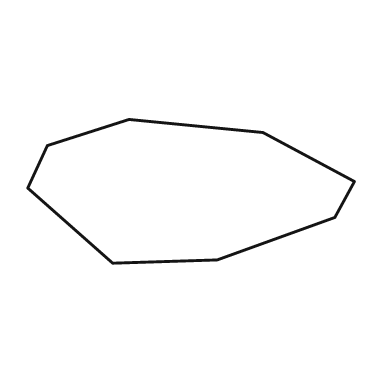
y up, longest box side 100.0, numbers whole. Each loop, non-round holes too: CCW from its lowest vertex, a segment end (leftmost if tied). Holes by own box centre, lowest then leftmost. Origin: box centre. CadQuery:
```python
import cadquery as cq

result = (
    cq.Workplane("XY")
    .moveTo(-24.0, -22.0)
    .lineTo(8.0, -21.0)
    .lineTo(44.0, -8.0)
    .lineTo(50.0, 3.0)
    .lineTo(22.0, 18.0)
    .lineTo(-19.0, 22.0)
    .lineTo(-44.0, 14.0)
    .lineTo(-50.0, 1.0)
    .close()
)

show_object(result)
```